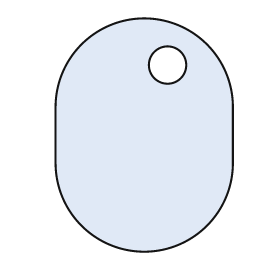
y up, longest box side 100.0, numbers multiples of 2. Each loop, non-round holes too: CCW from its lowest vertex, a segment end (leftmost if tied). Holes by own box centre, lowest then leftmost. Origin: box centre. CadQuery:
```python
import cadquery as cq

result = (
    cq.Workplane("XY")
    .moveTo(-38.0, -12.0)
    .threePointArc((0.0, -50.0), (38.0, -12.0))
    .lineTo(38.0, 12.0)
    .threePointArc((0.0, 50.0), (-38.0, 12.0))
    .close()
    .moveTo(10.0, 30.0)
    .circle(8.0)
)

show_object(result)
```